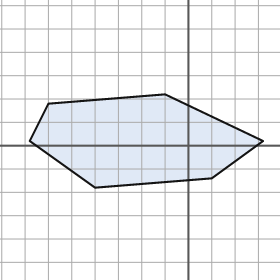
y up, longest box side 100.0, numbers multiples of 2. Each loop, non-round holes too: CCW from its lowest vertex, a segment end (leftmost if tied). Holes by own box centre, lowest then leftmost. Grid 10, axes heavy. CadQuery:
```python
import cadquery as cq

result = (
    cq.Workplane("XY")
    .moveTo(-40.0, -18.0)
    .lineTo(10.0, -14.0)
    .lineTo(32.0, 2.0)
    .lineTo(-10.0, 22.0)
    .lineTo(-60.0, 18.0)
    .lineTo(-68.0, 2.0)
    .close()
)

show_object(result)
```